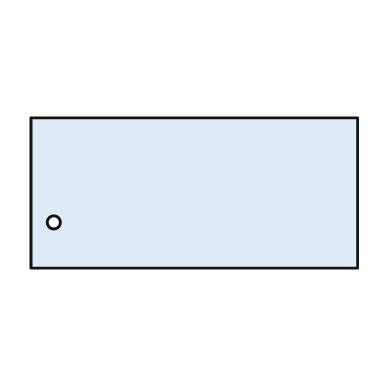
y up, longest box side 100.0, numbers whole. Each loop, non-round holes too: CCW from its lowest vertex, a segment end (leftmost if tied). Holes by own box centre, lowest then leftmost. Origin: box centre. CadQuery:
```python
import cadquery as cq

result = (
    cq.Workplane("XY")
    .moveTo(-50.0, -23.0)
    .lineTo(50.0, -23.0)
    .lineTo(50.0, 23.0)
    .lineTo(-50.0, 23.0)
    .close()
    .moveTo(-43.0, -9.0)
    .circle(2.0)
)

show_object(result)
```